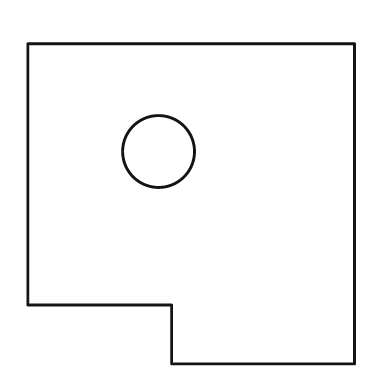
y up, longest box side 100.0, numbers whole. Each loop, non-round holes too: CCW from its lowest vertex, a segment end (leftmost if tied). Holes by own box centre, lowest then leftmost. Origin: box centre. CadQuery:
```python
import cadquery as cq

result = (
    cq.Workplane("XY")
    .moveTo(-6.0, -49.0)
    .lineTo(50.0, -49.0)
    .lineTo(50.0, 49.0)
    .lineTo(-50.0, 49.0)
    .lineTo(-50.0, -31.0)
    .lineTo(-6.0, -31.0)
    .close()
    .moveTo(-10.0, 16.0)
    .circle(11.0)
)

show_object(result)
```